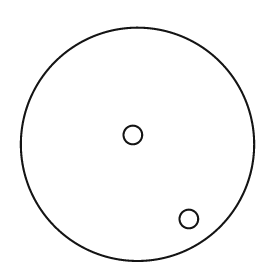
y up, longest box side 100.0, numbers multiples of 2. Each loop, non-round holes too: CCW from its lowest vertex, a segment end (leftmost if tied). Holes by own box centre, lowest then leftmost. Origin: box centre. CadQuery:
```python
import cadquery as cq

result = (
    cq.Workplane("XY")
    .moveTo(0.0, 0.0)
    .circle(50.0)
    .moveTo(22.0, -32.0)
    .circle(4.0)
    .moveTo(-2.0, 4.0)
    .circle(4.0)
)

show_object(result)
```